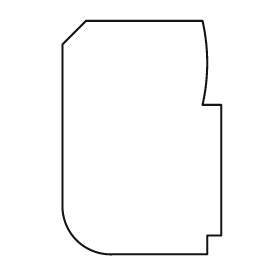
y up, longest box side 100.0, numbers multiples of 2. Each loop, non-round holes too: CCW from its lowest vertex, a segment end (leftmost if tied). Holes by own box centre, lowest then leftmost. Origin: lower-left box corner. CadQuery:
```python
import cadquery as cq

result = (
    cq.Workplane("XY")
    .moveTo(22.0, 0.0)
    .lineTo(62.0, 0.0)
    .lineTo(62.0, 8.0)
    .lineTo(68.0, 8.0)
    .lineTo(68.0, 64.0)
    .lineTo(60.0, 64.0)
    .threePointArc((62.0, 82.0), (60.0, 100.0))
    .lineTo(10.0, 100.0)
    .lineTo(0.0, 90.0)
    .lineTo(0.0, 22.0)
    .threePointArc((6.0, 6.0), (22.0, 0.0))
    .close()
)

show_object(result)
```